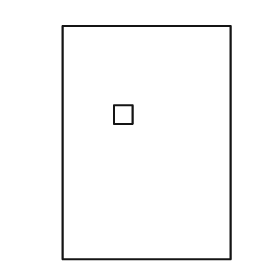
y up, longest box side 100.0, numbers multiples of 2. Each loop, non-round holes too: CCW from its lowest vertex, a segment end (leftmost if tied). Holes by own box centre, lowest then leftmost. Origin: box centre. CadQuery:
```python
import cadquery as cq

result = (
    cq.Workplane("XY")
    .moveTo(-36.0, -50.0)
    .lineTo(36.0, -50.0)
    .lineTo(36.0, 50.0)
    .lineTo(-36.0, 50.0)
    .close()
    .moveTo(-14.0, 8.0)
    .lineTo(-6.0, 8.0)
    .lineTo(-6.0, 16.0)
    .lineTo(-14.0, 16.0)
    .close()
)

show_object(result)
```